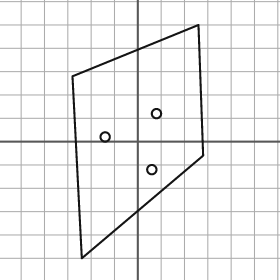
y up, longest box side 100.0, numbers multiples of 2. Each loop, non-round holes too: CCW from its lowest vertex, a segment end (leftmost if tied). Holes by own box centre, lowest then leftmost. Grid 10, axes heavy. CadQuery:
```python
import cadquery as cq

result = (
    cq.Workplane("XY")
    .moveTo(-24.0, -50.0)
    .lineTo(28.0, -6.0)
    .lineTo(26.0, 50.0)
    .lineTo(-28.0, 28.0)
    .close()
    .moveTo(6.0, -12.0)
    .circle(2.0)
    .moveTo(-14.0, 2.0)
    .circle(2.0)
    .moveTo(8.0, 12.0)
    .circle(2.0)
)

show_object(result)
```